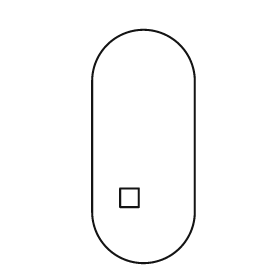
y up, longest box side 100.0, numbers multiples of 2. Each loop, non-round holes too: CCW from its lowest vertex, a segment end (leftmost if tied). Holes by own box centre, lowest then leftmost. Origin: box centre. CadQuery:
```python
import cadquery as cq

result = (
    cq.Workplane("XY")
    .moveTo(-22.0, -28.0)
    .threePointArc((0.0, -50.0), (22.0, -28.0))
    .lineTo(22.0, 28.0)
    .threePointArc((0.0, 50.0), (-22.0, 28.0))
    .close()
    .moveTo(-10.0, -26.0)
    .lineTo(-2.0, -26.0)
    .lineTo(-2.0, -18.0)
    .lineTo(-10.0, -18.0)
    .close()
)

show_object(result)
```